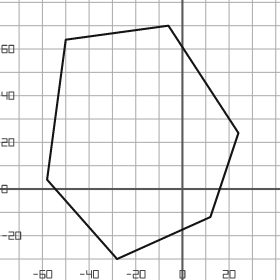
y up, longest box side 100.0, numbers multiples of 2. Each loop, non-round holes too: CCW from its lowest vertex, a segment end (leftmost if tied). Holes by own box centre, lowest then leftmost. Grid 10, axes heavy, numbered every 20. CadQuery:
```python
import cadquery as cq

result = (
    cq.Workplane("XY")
    .moveTo(-28.0, -30.0)
    .lineTo(12.0, -12.0)
    .lineTo(24.0, 24.0)
    .lineTo(-6.0, 70.0)
    .lineTo(-50.0, 64.0)
    .lineTo(-58.0, 4.0)
    .close()
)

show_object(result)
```